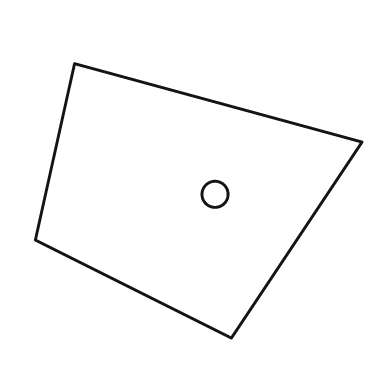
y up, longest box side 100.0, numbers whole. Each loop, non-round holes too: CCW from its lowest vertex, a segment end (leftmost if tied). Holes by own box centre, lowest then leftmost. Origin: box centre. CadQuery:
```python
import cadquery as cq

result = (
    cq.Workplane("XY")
    .moveTo(10.0, -42.0)
    .lineTo(50.0, 18.0)
    .lineTo(-38.0, 42.0)
    .lineTo(-50.0, -12.0)
    .close()
    .moveTo(5.0, 2.0)
    .circle(4.0)
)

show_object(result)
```